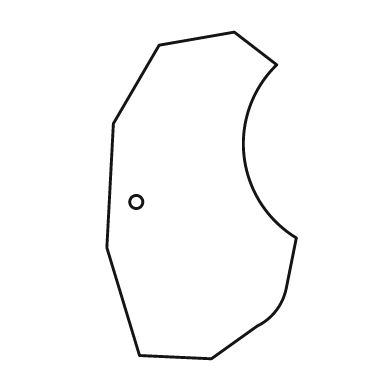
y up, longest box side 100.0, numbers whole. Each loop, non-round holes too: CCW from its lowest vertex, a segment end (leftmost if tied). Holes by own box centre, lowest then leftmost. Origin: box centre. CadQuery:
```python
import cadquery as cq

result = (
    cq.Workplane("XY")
    .moveTo(3.0, -50.0)
    .lineTo(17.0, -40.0)
    .threePointArc((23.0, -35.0), (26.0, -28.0))
    .lineTo(29.0, -13.0)
    .threePointArc((13.0, 12.0), (23.0, 40.0))
    .lineTo(10.0, 50.0)
    .lineTo(-13.0, 46.0)
    .lineTo(-27.0, 22.0)
    .lineTo(-29.0, -16.0)
    .lineTo(-19.0, -49.0)
    .close()
    .moveTo(-20.0, -2.0)
    .circle(2.0)
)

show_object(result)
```